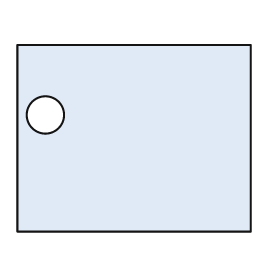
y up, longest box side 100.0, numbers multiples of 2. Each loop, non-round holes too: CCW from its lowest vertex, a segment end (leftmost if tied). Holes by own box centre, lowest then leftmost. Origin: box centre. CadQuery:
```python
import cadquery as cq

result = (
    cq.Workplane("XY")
    .moveTo(-50.0, -40.0)
    .lineTo(50.0, -40.0)
    .lineTo(50.0, 40.0)
    .lineTo(-50.0, 40.0)
    .close()
    .moveTo(-38.0, 10.0)
    .circle(8.0)
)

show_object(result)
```